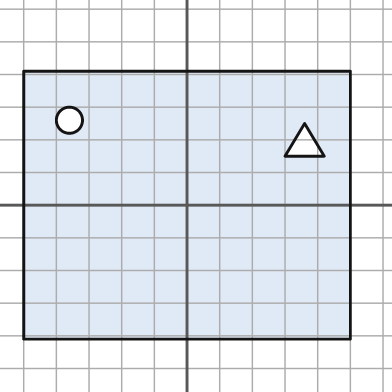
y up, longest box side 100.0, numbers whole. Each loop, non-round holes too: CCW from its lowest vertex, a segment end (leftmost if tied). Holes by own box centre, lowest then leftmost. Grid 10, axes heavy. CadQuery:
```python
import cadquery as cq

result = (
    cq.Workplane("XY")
    .moveTo(-50.0, -41.0)
    .lineTo(50.0, -41.0)
    .lineTo(50.0, 41.0)
    .lineTo(-50.0, 41.0)
    .close()
    .moveTo(30.0, 15.0)
    .lineTo(42.0, 15.0)
    .lineTo(36.0, 25.0)
    .close()
    .moveTo(-36.0, 26.0)
    .circle(4.0)
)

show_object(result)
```